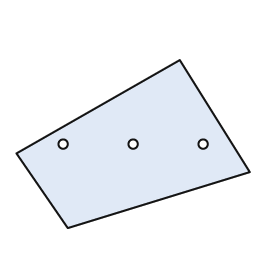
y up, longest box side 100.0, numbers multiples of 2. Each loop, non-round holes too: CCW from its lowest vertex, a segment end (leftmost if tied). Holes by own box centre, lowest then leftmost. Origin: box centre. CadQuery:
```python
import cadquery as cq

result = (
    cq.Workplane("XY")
    .moveTo(-28.0, -36.0)
    .lineTo(50.0, -12.0)
    .lineTo(20.0, 36.0)
    .lineTo(-50.0, -4.0)
    .close()
    .moveTo(-30.0, 0.0)
    .circle(2.0)
    .moveTo(0.0, 0.0)
    .circle(2.0)
    .moveTo(30.0, 0.0)
    .circle(2.0)
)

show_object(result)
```